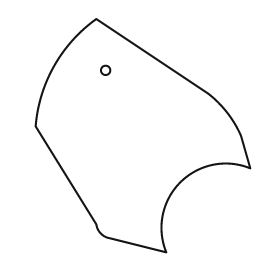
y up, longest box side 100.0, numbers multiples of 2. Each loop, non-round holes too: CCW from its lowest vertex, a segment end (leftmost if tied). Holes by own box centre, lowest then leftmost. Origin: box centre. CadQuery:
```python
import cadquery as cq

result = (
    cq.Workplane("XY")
    .moveTo(10.0, -50.0)
    .threePointArc((16.0, -20.0), (46.0, -14.0))
    .lineTo(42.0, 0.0)
    .threePointArc((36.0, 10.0), (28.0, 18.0))
    .lineTo(-20.0, 50.0)
    .threePointArc((-38.0, 30.0), (-46.0, 4.0))
    .lineTo(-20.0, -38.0)
    .threePointArc((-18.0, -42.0), (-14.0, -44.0))
    .close()
    .moveTo(-16.0, 28.0)
    .circle(2.0)
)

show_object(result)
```